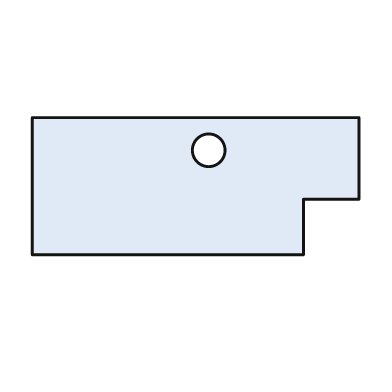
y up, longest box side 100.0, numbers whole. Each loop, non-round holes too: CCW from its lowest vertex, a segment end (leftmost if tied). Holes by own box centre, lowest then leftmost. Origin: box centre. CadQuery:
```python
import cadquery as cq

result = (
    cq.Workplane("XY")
    .moveTo(-50.0, -21.0)
    .lineTo(33.0, -21.0)
    .lineTo(33.0, -4.0)
    .lineTo(50.0, -4.0)
    .lineTo(50.0, 21.0)
    .lineTo(-50.0, 21.0)
    .close()
    .moveTo(4.0, 11.0)
    .circle(5.0)
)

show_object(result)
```